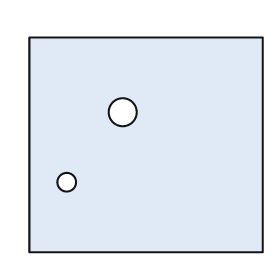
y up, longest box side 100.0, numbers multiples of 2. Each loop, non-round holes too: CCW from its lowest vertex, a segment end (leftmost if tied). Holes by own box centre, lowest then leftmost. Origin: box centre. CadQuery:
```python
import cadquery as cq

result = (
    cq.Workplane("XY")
    .moveTo(-50.0, -46.0)
    .lineTo(50.0, -46.0)
    .lineTo(50.0, 46.0)
    .lineTo(-50.0, 46.0)
    .close()
    .moveTo(-34.0, -16.0)
    .circle(4.0)
    .moveTo(-10.0, 14.0)
    .circle(6.0)
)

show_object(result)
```